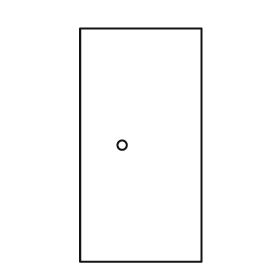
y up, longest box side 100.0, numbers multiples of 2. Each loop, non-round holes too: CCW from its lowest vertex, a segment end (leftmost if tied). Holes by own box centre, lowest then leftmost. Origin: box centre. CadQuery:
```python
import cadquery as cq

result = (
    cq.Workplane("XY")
    .moveTo(-26.0, -50.0)
    .lineTo(26.0, -50.0)
    .lineTo(26.0, 50.0)
    .lineTo(-26.0, 50.0)
    .close()
    .moveTo(-8.0, 0.0)
    .circle(2.0)
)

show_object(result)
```